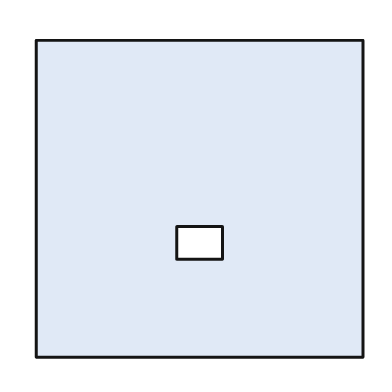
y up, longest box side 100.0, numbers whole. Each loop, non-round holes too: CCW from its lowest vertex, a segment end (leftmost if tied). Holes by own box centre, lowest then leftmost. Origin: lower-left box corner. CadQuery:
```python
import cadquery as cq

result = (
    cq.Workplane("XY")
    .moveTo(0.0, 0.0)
    .lineTo(100.0, 0.0)
    .lineTo(100.0, 97.0)
    .lineTo(0.0, 97.0)
    .close()
    .moveTo(43.0, 30.0)
    .lineTo(57.0, 30.0)
    .lineTo(57.0, 40.0)
    .lineTo(43.0, 40.0)
    .close()
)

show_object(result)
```